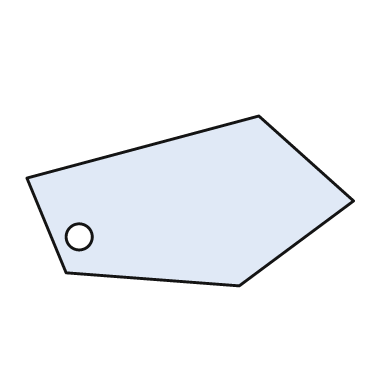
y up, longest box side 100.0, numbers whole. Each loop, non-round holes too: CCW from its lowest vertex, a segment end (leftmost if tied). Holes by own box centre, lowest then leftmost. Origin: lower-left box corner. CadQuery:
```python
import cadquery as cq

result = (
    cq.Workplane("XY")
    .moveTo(65.0, 0.0)
    .lineTo(100.0, 26.0)
    .lineTo(71.0, 52.0)
    .lineTo(0.0, 33.0)
    .lineTo(12.0, 4.0)
    .close()
    .moveTo(16.0, 15.0)
    .circle(4.0)
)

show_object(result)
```